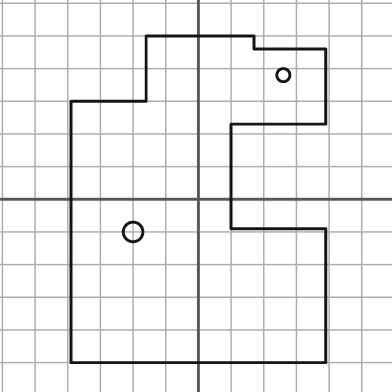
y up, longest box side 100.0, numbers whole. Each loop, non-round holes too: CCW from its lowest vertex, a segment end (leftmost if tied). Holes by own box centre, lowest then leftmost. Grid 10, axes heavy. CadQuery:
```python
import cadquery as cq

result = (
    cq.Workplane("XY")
    .moveTo(-39.0, -50.0)
    .lineTo(39.0, -50.0)
    .lineTo(39.0, -9.0)
    .lineTo(10.0, -9.0)
    .lineTo(10.0, 23.0)
    .lineTo(39.0, 23.0)
    .lineTo(39.0, 46.0)
    .lineTo(17.0, 46.0)
    .lineTo(17.0, 50.0)
    .lineTo(-16.0, 50.0)
    .lineTo(-16.0, 30.0)
    .lineTo(-39.0, 30.0)
    .close()
    .moveTo(-20.0, -10.0)
    .circle(3.0)
    .moveTo(26.0, 38.0)
    .circle(2.0)
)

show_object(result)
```